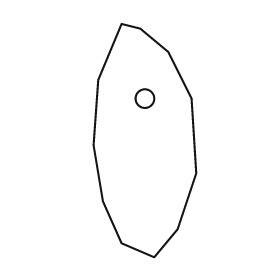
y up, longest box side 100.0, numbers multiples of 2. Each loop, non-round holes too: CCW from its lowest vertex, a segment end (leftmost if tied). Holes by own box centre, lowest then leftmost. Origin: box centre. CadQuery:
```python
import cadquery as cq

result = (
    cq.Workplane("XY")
    .moveTo(4.0, -50.0)
    .lineTo(14.0, -38.0)
    .lineTo(22.0, -14.0)
    .lineTo(20.0, 18.0)
    .lineTo(10.0, 38.0)
    .lineTo(-2.0, 48.0)
    .lineTo(-10.0, 50.0)
    .lineTo(-20.0, 26.0)
    .lineTo(-22.0, -2.0)
    .lineTo(-18.0, -26.0)
    .lineTo(-10.0, -44.0)
    .close()
    .moveTo(0.0, 18.0)
    .circle(4.0)
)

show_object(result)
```